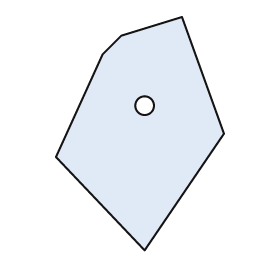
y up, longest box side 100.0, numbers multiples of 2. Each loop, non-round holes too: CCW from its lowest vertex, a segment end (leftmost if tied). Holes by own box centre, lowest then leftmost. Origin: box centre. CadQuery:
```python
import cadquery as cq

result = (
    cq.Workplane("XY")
    .moveTo(2.0, -50.0)
    .lineTo(36.0, 0.0)
    .lineTo(18.0, 50.0)
    .lineTo(-8.0, 42.0)
    .lineTo(-16.0, 34.0)
    .lineTo(-36.0, -10.0)
    .close()
    .moveTo(2.0, 12.0)
    .circle(4.0)
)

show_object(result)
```